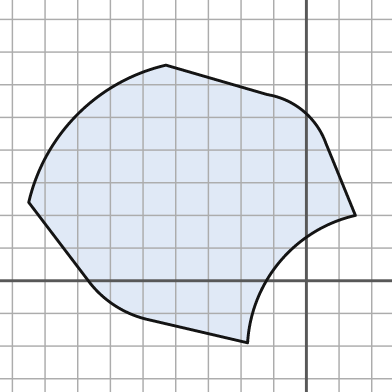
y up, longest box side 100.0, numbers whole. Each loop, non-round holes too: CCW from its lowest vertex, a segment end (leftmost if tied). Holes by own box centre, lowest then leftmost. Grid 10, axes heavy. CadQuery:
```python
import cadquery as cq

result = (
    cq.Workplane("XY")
    .moveTo(-18.0, -19.0)
    .threePointArc((-8.0, 6.0), (15.0, 20.0))
    .lineTo(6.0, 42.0)
    .threePointArc((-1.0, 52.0), (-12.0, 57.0))
    .lineTo(-43.0, 66.0)
    .threePointArc((-70.0, 51.0), (-85.0, 24.0))
    .lineTo(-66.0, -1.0)
    .threePointArc((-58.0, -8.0), (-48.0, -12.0))
    .close()
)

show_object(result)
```